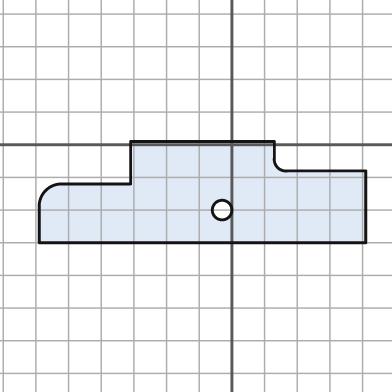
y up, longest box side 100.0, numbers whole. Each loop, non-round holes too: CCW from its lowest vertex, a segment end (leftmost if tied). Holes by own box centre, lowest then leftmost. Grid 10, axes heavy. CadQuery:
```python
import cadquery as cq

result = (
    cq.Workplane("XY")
    .moveTo(-59.0, -30.0)
    .lineTo(41.0, -30.0)
    .lineTo(41.0, -8.0)
    .lineTo(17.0, -8.0)
    .threePointArc((14.0, -7.0), (13.0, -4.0))
    .lineTo(13.0, 1.0)
    .lineTo(-31.0, 1.0)
    .lineTo(-31.0, -12.0)
    .lineTo(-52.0, -12.0)
    .threePointArc((-57.0, -14.0), (-59.0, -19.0))
    .close()
    .moveTo(-3.0, -20.0)
    .circle(3.0)
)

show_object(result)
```